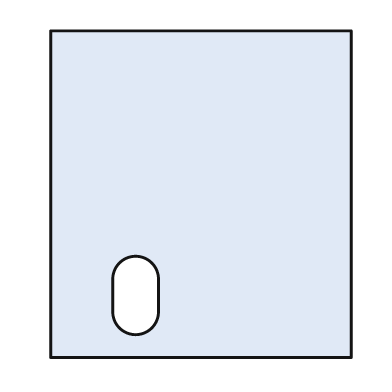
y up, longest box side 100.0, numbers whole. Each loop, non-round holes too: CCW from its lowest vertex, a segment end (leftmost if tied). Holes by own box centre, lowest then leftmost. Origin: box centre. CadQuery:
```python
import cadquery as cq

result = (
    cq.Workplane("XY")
    .moveTo(-46.0, -50.0)
    .lineTo(46.0, -50.0)
    .lineTo(46.0, 50.0)
    .lineTo(-46.0, 50.0)
    .close()
    .moveTo(-27.0, -36.0)
    .threePointArc((-20.0, -43.0), (-13.0, -36.0))
    .lineTo(-13.0, -26.0)
    .threePointArc((-20.0, -19.0), (-27.0, -26.0))
    .close()
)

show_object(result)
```